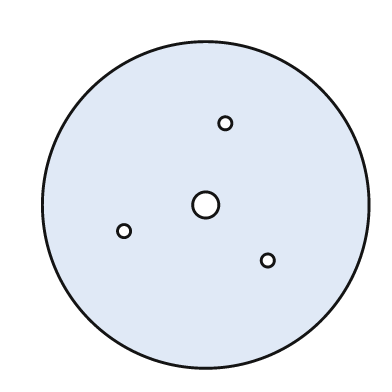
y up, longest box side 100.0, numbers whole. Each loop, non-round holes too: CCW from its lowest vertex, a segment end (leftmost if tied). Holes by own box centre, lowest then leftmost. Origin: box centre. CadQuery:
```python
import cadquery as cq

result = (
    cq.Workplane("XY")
    .moveTo(0.0, 0.0)
    .circle(50.0)
    .moveTo(19.0, -17.0)
    .circle(2.0)
    .moveTo(-25.0, -8.0)
    .circle(2.0)
    .moveTo(0.0, 0.0)
    .circle(4.0)
    .moveTo(6.0, 25.0)
    .circle(2.0)
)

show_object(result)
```